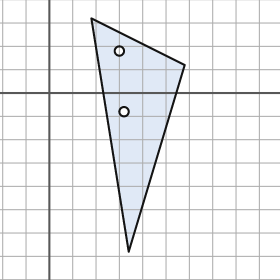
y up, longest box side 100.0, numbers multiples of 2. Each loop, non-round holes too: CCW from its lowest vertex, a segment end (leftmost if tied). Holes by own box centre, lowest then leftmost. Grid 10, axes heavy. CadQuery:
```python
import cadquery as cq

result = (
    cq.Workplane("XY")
    .moveTo(34.0, -68.0)
    .lineTo(58.0, 12.0)
    .lineTo(18.0, 32.0)
    .close()
    .moveTo(32.0, -8.0)
    .circle(2.0)
    .moveTo(30.0, 18.0)
    .circle(2.0)
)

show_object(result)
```